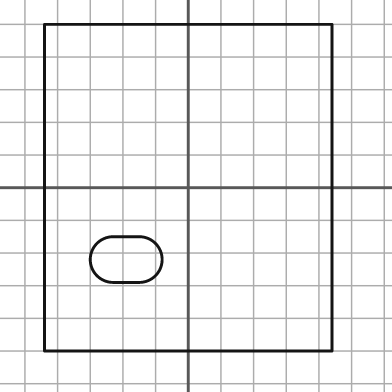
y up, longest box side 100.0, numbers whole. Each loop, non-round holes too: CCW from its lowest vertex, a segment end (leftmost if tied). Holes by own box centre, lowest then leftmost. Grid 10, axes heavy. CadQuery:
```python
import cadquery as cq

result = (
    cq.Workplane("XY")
    .moveTo(-44.0, -50.0)
    .lineTo(44.0, -50.0)
    .lineTo(44.0, 50.0)
    .lineTo(-44.0, 50.0)
    .close()
    .moveTo(-23.0, -29.0)
    .lineTo(-15.0, -29.0)
    .threePointArc((-8.0, -22.0), (-15.0, -15.0))
    .lineTo(-23.0, -15.0)
    .threePointArc((-30.0, -22.0), (-23.0, -29.0))
    .close()
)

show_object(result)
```